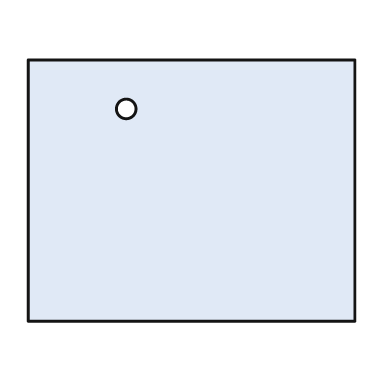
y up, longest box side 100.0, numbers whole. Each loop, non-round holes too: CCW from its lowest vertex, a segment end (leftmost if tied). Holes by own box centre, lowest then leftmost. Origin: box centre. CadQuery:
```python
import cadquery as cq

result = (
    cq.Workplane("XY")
    .moveTo(-50.0, -40.0)
    .lineTo(50.0, -40.0)
    .lineTo(50.0, 40.0)
    .lineTo(-50.0, 40.0)
    .close()
    .moveTo(-20.0, 25.0)
    .circle(3.0)
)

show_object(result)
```